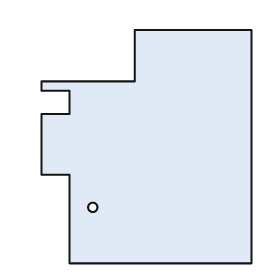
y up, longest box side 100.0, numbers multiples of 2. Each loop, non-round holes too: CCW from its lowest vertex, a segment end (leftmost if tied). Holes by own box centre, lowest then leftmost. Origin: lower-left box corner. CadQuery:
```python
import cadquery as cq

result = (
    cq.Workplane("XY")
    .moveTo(12.0, 0.0)
    .lineTo(90.0, 0.0)
    .lineTo(90.0, 100.0)
    .lineTo(40.0, 100.0)
    .lineTo(40.0, 78.0)
    .lineTo(0.0, 78.0)
    .lineTo(0.0, 74.0)
    .lineTo(12.0, 74.0)
    .lineTo(12.0, 64.0)
    .lineTo(0.0, 64.0)
    .lineTo(0.0, 38.0)
    .lineTo(12.0, 38.0)
    .close()
    .moveTo(22.0, 24.0)
    .circle(2.0)
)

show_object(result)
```